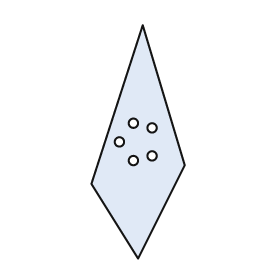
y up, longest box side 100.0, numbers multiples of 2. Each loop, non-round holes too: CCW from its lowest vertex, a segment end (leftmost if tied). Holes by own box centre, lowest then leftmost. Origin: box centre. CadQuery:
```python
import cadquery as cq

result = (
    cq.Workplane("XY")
    .moveTo(0.0, -50.0)
    .lineTo(20.0, -10.0)
    .lineTo(2.0, 50.0)
    .lineTo(-20.0, -18.0)
    .close()
    .moveTo(-2.0, -8.0)
    .circle(2.0)
    .moveTo(6.0, -6.0)
    .circle(2.0)
    .moveTo(-8.0, 0.0)
    .circle(2.0)
    .moveTo(6.0, 6.0)
    .circle(2.0)
    .moveTo(-2.0, 8.0)
    .circle(2.0)
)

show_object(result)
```